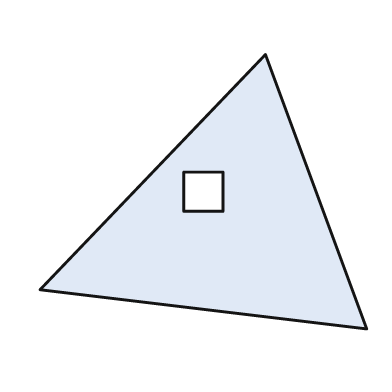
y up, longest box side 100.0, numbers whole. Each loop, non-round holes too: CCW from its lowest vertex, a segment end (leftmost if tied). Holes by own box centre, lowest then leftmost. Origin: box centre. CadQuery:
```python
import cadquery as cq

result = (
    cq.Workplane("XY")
    .moveTo(50.0, -42.0)
    .lineTo(19.0, 42.0)
    .lineTo(-50.0, -30.0)
    .close()
    .moveTo(-6.0, -6.0)
    .lineTo(6.0, -6.0)
    .lineTo(6.0, 6.0)
    .lineTo(-6.0, 6.0)
    .close()
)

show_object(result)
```